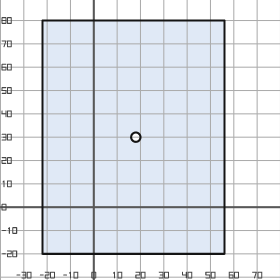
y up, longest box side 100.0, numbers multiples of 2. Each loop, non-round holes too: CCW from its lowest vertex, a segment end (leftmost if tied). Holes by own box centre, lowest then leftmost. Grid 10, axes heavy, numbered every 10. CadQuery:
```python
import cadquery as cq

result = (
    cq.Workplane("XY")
    .moveTo(-22.0, -20.0)
    .lineTo(56.0, -20.0)
    .lineTo(56.0, 80.0)
    .lineTo(-22.0, 80.0)
    .close()
    .moveTo(18.0, 30.0)
    .circle(2.0)
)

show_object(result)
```